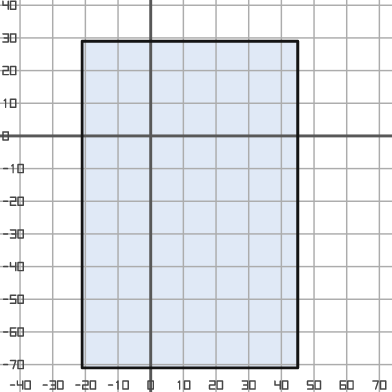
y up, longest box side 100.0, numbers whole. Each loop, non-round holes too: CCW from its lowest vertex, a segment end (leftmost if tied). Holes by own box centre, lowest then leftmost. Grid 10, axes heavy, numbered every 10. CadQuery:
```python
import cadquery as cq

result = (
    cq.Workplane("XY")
    .moveTo(-21.0, -71.0)
    .lineTo(45.0, -71.0)
    .lineTo(45.0, 29.0)
    .lineTo(-21.0, 29.0)
    .close()
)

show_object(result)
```